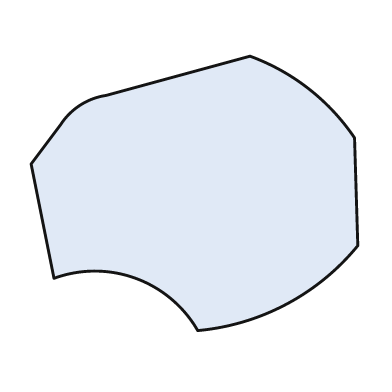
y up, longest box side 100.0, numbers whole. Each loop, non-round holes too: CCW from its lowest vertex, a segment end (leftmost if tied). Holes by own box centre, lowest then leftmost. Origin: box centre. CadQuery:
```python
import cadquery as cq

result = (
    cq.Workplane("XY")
    .moveTo(1.0, -42.0)
    .threePointArc((28.0, -34.0), (50.0, -16.0))
    .lineTo(49.0, 17.0)
    .threePointArc((35.0, 32.0), (17.0, 42.0))
    .lineTo(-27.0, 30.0)
    .threePointArc((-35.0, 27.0), (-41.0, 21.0))
    .lineTo(-50.0, 9.0)
    .lineTo(-43.0, -26.0)
    .threePointArc((-18.0, -26.0), (1.0, -42.0))
    .close()
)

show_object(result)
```